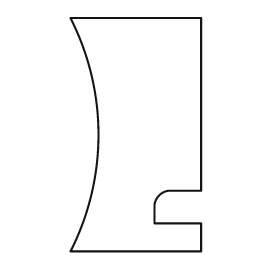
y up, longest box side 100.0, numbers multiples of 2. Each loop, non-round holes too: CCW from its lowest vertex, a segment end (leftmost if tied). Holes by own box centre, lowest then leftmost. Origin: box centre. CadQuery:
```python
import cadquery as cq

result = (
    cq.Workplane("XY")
    .moveTo(-28.0, -50.0)
    .lineTo(28.0, -50.0)
    .lineTo(28.0, -38.0)
    .lineTo(8.0, -38.0)
    .lineTo(8.0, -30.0)
    .threePointArc((10.0, -26.0), (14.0, -24.0))
    .lineTo(28.0, -24.0)
    .lineTo(28.0, 50.0)
    .lineTo(-28.0, 50.0)
    .threePointArc((-16.0, 0.0), (-28.0, -50.0))
    .close()
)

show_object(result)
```